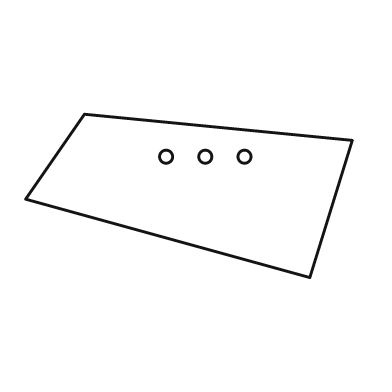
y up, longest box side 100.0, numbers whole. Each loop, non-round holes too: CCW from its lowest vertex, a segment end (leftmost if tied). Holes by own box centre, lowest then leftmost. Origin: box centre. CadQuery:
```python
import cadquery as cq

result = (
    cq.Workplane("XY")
    .moveTo(37.0, -25.0)
    .lineTo(50.0, 17.0)
    .lineTo(-32.0, 25.0)
    .lineTo(-50.0, -1.0)
    .close()
    .moveTo(-7.0, 12.0)
    .circle(2.0)
    .moveTo(5.0, 12.0)
    .circle(2.0)
    .moveTo(17.0, 12.0)
    .circle(2.0)
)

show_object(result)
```